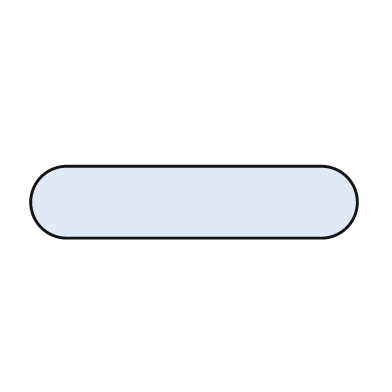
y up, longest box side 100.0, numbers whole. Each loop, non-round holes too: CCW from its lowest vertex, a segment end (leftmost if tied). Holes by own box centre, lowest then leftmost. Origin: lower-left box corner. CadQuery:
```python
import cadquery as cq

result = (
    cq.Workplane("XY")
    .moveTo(11.0, 0.0)
    .lineTo(89.0, 0.0)
    .threePointArc((100.0, 11.0), (89.0, 22.0))
    .lineTo(11.0, 22.0)
    .threePointArc((0.0, 11.0), (11.0, 0.0))
    .close()
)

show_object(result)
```